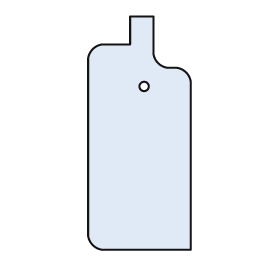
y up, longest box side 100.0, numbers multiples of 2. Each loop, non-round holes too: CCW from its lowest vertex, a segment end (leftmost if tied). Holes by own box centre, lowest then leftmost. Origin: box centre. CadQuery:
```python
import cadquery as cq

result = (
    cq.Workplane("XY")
    .moveTo(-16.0, -50.0)
    .lineTo(22.0, -50.0)
    .lineTo(22.0, 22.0)
    .threePointArc((20.0, 26.0), (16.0, 28.0))
    .lineTo(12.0, 28.0)
    .threePointArc((8.0, 30.0), (6.0, 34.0))
    .lineTo(6.0, 50.0)
    .lineTo(-4.0, 50.0)
    .lineTo(-4.0, 38.0)
    .lineTo(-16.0, 38.0)
    .threePointArc((-20.0, 36.0), (-22.0, 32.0))
    .lineTo(-22.0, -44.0)
    .threePointArc((-20.0, -48.0), (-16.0, -50.0))
    .close()
    .moveTo(2.0, 20.0)
    .circle(2.0)
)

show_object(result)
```